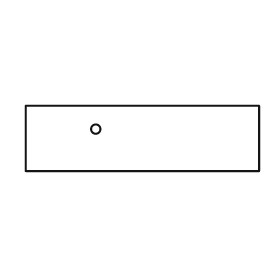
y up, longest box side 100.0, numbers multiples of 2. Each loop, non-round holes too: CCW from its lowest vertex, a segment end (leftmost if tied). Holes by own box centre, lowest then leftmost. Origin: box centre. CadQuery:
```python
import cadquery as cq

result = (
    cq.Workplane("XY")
    .moveTo(-50.0, -14.0)
    .lineTo(50.0, -14.0)
    .lineTo(50.0, 14.0)
    .lineTo(-50.0, 14.0)
    .close()
    .moveTo(-20.0, 4.0)
    .circle(2.0)
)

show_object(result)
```